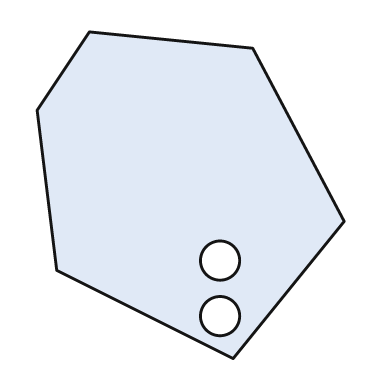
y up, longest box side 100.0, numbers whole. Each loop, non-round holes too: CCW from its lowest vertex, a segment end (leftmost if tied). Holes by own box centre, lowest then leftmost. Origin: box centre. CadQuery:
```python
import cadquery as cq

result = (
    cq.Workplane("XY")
    .moveTo(13.0, -50.0)
    .lineTo(47.0, -8.0)
    .lineTo(19.0, 45.0)
    .lineTo(-31.0, 50.0)
    .lineTo(-47.0, 26.0)
    .lineTo(-41.0, -23.0)
    .close()
    .moveTo(9.0, -37.0)
    .circle(6.0)
    .moveTo(9.0, -20.0)
    .circle(6.0)
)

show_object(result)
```